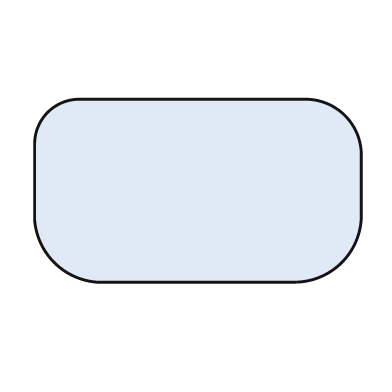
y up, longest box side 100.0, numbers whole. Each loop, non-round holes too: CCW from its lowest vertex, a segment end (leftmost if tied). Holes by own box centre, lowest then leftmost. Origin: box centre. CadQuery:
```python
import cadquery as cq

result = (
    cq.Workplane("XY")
    .moveTo(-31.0, -28.0)
    .lineTo(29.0, -28.0)
    .threePointArc((44.0, -22.0), (50.0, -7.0))
    .lineTo(50.0, 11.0)
    .threePointArc((45.0, 23.0), (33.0, 28.0))
    .lineTo(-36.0, 28.0)
    .threePointArc((-46.0, 24.0), (-50.0, 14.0))
    .lineTo(-50.0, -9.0)
    .threePointArc((-44.0, -22.0), (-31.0, -28.0))
    .close()
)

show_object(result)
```